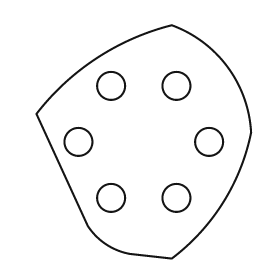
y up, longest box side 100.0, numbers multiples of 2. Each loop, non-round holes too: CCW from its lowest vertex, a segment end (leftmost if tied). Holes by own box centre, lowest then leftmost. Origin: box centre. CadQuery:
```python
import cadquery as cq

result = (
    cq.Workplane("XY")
    .moveTo(12.0, -50.0)
    .threePointArc((34.0, -26.0), (46.0, 4.0))
    .threePointArc((36.0, 32.0), (12.0, 50.0))
    .threePointArc((-20.0, 36.0), (-46.0, 12.0))
    .lineTo(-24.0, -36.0)
    .threePointArc((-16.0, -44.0), (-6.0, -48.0))
    .close()
    .moveTo(-14.0, -24.0)
    .circle(6.0)
    .moveTo(14.0, -24.0)
    .circle(6.0)
    .moveTo(-28.0, 0.0)
    .circle(6.0)
    .moveTo(28.0, 0.0)
    .circle(6.0)
    .moveTo(-14.0, 24.0)
    .circle(6.0)
    .moveTo(14.0, 24.0)
    .circle(6.0)
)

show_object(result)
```